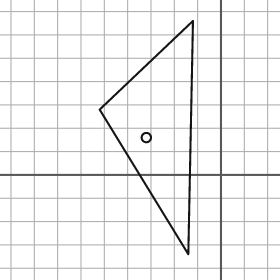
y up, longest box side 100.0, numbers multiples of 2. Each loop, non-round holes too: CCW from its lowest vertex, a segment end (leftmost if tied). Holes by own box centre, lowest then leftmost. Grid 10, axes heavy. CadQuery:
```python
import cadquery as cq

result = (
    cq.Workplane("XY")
    .moveTo(-14.0, -34.0)
    .lineTo(-12.0, 66.0)
    .lineTo(-52.0, 28.0)
    .close()
    .moveTo(-32.0, 16.0)
    .circle(2.0)
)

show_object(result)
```